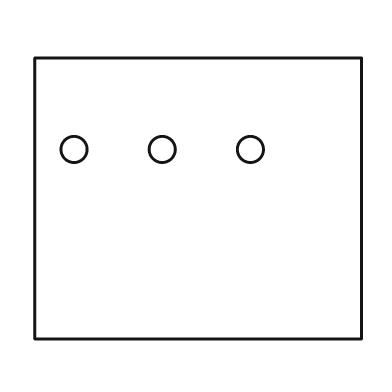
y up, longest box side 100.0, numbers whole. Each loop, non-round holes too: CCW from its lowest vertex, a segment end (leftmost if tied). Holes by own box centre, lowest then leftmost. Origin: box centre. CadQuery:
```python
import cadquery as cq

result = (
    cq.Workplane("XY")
    .moveTo(-50.0, -43.0)
    .lineTo(50.0, -43.0)
    .lineTo(50.0, 43.0)
    .lineTo(-50.0, 43.0)
    .close()
    .moveTo(-38.0, 15.0)
    .circle(4.0)
    .moveTo(-11.0, 15.0)
    .circle(4.0)
    .moveTo(16.0, 15.0)
    .circle(4.0)
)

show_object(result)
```